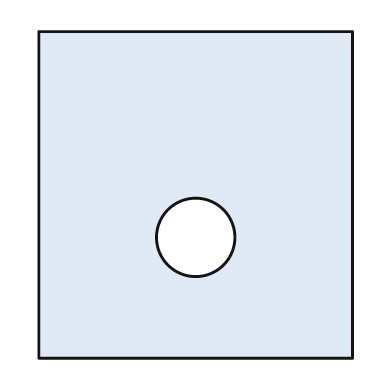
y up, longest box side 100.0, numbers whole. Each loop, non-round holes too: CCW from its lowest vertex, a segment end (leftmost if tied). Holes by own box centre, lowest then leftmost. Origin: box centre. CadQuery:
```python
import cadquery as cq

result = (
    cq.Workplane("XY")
    .moveTo(-48.0, -50.0)
    .lineTo(48.0, -50.0)
    .lineTo(48.0, 50.0)
    .lineTo(-48.0, 50.0)
    .close()
    .moveTo(0.0, -13.0)
    .circle(12.0)
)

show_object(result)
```